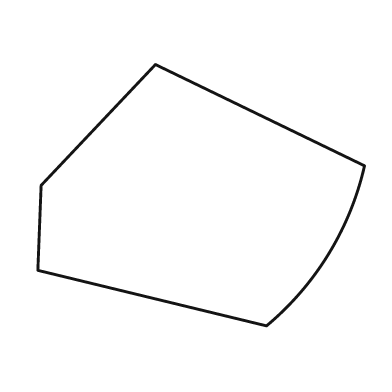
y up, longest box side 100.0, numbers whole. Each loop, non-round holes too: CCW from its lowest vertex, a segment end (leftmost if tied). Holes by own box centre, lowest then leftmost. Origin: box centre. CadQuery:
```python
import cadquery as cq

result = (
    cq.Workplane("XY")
    .moveTo(20.0, -40.0)
    .threePointArc((39.0, -18.0), (50.0, 9.0))
    .lineTo(-14.0, 40.0)
    .lineTo(-49.0, 3.0)
    .lineTo(-50.0, -23.0)
    .close()
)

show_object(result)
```